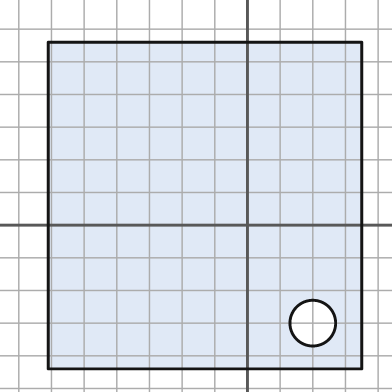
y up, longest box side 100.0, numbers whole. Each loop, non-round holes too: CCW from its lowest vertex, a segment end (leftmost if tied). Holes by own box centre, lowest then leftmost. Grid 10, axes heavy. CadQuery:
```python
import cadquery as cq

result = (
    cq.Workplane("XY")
    .moveTo(-61.0, -44.0)
    .lineTo(35.0, -44.0)
    .lineTo(35.0, 56.0)
    .lineTo(-61.0, 56.0)
    .close()
    .moveTo(20.0, -30.0)
    .circle(7.0)
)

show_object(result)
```